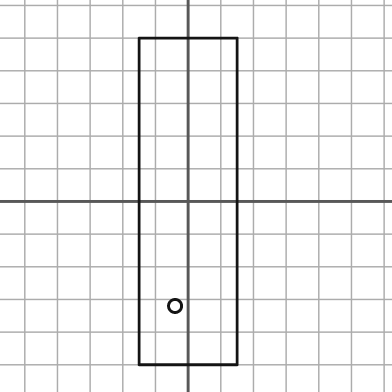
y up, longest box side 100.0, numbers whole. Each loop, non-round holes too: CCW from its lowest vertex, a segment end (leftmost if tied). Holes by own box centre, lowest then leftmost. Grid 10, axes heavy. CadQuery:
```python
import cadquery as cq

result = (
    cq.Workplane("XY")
    .moveTo(-15.0, -50.0)
    .lineTo(15.0, -50.0)
    .lineTo(15.0, 50.0)
    .lineTo(-15.0, 50.0)
    .close()
    .moveTo(-4.0, -32.0)
    .circle(2.0)
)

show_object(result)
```